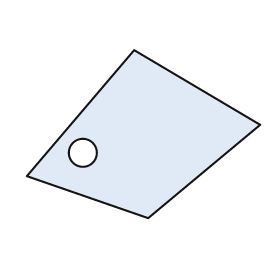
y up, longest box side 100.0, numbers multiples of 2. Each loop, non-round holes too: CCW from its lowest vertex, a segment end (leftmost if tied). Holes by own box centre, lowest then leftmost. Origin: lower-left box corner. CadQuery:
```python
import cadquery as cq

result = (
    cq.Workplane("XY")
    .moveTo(52.0, 0.0)
    .lineTo(100.0, 40.0)
    .lineTo(46.0, 72.0)
    .lineTo(0.0, 18.0)
    .close()
    .moveTo(24.0, 28.0)
    .circle(6.0)
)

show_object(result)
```